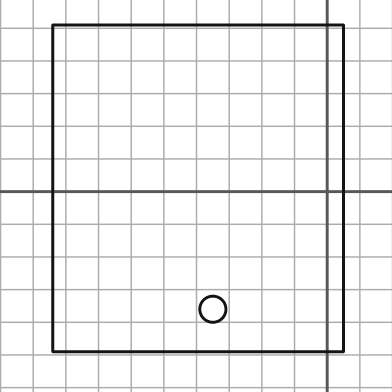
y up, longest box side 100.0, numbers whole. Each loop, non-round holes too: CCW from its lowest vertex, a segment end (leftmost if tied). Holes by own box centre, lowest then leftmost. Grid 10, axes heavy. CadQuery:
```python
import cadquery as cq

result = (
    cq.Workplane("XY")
    .moveTo(-84.0, -49.0)
    .lineTo(5.0, -49.0)
    .lineTo(5.0, 51.0)
    .lineTo(-84.0, 51.0)
    .close()
    .moveTo(-35.0, -36.0)
    .circle(4.0)
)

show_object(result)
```